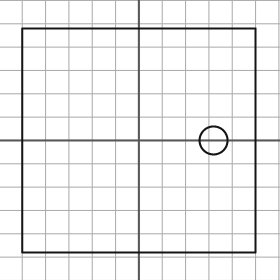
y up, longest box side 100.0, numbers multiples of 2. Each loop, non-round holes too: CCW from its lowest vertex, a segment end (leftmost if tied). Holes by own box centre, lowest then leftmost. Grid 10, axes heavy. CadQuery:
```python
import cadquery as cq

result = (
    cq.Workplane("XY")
    .moveTo(-50.0, -48.0)
    .lineTo(50.0, -48.0)
    .lineTo(50.0, 48.0)
    .lineTo(-50.0, 48.0)
    .close()
    .moveTo(32.0, 0.0)
    .circle(6.0)
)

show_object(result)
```